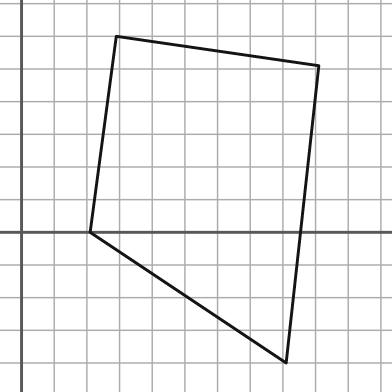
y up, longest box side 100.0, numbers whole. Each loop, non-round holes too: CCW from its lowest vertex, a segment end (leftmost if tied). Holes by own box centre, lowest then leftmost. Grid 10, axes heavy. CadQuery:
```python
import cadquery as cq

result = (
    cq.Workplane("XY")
    .moveTo(81.0, -40.0)
    .lineTo(91.0, 51.0)
    .lineTo(29.0, 60.0)
    .lineTo(21.0, 0.0)
    .close()
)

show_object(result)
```